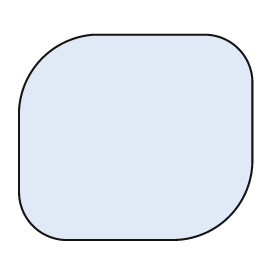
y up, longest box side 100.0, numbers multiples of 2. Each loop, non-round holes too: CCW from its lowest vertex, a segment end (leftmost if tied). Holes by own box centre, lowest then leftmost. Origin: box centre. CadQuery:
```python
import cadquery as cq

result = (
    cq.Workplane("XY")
    .moveTo(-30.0, -44.0)
    .lineTo(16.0, -44.0)
    .threePointArc((40.0, -34.0), (50.0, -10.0))
    .lineTo(50.0, 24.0)
    .threePointArc((44.0, 38.0), (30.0, 44.0))
    .lineTo(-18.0, 44.0)
    .threePointArc((-40.0, 34.0), (-50.0, 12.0))
    .lineTo(-50.0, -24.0)
    .threePointArc((-44.0, -38.0), (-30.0, -44.0))
    .close()
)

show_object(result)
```